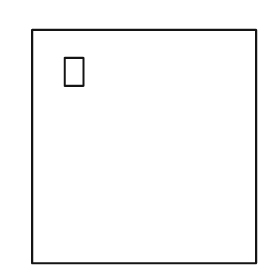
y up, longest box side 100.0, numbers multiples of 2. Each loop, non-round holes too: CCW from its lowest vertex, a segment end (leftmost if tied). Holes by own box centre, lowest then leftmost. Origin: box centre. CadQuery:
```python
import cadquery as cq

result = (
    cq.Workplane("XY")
    .moveTo(-48.0, -50.0)
    .lineTo(48.0, -50.0)
    .lineTo(48.0, 50.0)
    .lineTo(-48.0, 50.0)
    .close()
    .moveTo(-34.0, 26.0)
    .lineTo(-26.0, 26.0)
    .lineTo(-26.0, 38.0)
    .lineTo(-34.0, 38.0)
    .close()
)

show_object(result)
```